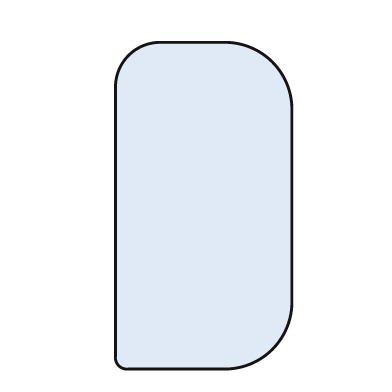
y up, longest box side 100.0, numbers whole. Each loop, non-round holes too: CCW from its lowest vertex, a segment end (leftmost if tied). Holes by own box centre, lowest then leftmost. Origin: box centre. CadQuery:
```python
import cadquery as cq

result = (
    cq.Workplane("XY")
    .moveTo(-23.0, -50.0)
    .lineTo(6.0, -50.0)
    .threePointArc((21.0, -44.0), (27.0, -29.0))
    .lineTo(27.0, 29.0)
    .threePointArc((21.0, 44.0), (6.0, 50.0))
    .lineTo(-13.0, 50.0)
    .threePointArc((-23.0, 46.0), (-27.0, 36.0))
    .lineTo(-27.0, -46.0)
    .threePointArc((-26.0, -49.0), (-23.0, -50.0))
    .close()
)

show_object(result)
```